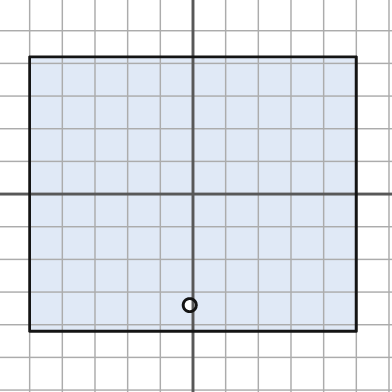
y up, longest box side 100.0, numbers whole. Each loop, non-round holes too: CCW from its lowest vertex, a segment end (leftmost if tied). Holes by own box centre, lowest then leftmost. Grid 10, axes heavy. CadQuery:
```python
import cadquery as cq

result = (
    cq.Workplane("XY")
    .moveTo(-50.0, -42.0)
    .lineTo(50.0, -42.0)
    .lineTo(50.0, 42.0)
    .lineTo(-50.0, 42.0)
    .close()
    .moveTo(-1.0, -34.0)
    .circle(2.0)
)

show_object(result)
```